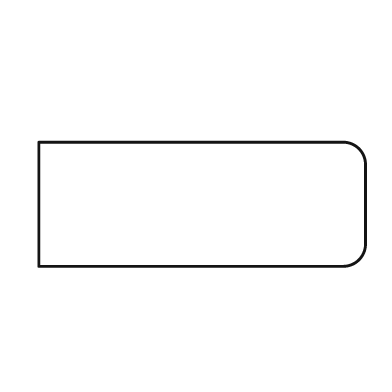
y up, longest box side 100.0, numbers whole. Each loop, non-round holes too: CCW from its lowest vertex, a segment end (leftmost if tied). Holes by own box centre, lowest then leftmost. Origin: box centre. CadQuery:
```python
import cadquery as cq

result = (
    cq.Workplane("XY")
    .moveTo(-50.0, -19.0)
    .lineTo(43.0, -19.0)
    .threePointArc((48.0, -17.0), (50.0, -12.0))
    .lineTo(50.0, 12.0)
    .threePointArc((48.0, 17.0), (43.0, 19.0))
    .lineTo(-50.0, 19.0)
    .close()
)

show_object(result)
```